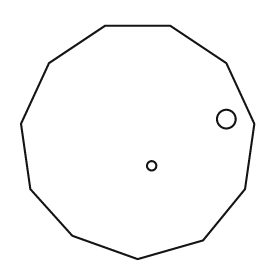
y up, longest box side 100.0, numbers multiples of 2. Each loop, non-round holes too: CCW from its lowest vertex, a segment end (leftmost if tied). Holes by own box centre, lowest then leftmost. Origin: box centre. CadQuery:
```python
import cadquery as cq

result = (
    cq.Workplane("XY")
    .moveTo(0.0, -50.0)
    .lineTo(28.0, -42.0)
    .lineTo(46.0, -20.0)
    .lineTo(50.0, 8.0)
    .lineTo(38.0, 34.0)
    .lineTo(14.0, 50.0)
    .lineTo(-14.0, 50.0)
    .lineTo(-38.0, 34.0)
    .lineTo(-50.0, 8.0)
    .lineTo(-46.0, -20.0)
    .lineTo(-28.0, -40.0)
    .close()
    .moveTo(6.0, -10.0)
    .circle(2.0)
    .moveTo(38.0, 10.0)
    .circle(4.0)
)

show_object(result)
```